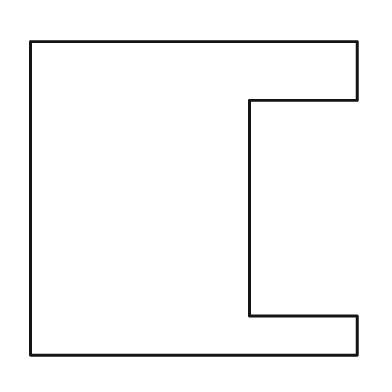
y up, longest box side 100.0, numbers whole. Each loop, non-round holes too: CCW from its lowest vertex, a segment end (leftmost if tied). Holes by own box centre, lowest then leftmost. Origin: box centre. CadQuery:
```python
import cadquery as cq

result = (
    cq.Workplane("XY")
    .moveTo(-50.0, -48.0)
    .lineTo(50.0, -48.0)
    .lineTo(50.0, -36.0)
    .lineTo(17.0, -36.0)
    .lineTo(17.0, 30.0)
    .lineTo(50.0, 30.0)
    .lineTo(50.0, 48.0)
    .lineTo(-50.0, 48.0)
    .close()
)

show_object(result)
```